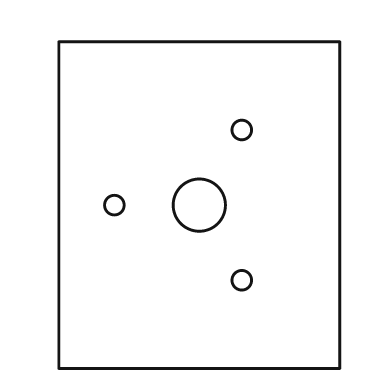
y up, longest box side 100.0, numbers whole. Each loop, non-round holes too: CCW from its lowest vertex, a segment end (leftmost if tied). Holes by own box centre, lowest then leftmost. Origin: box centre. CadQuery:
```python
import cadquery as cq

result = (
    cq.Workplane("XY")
    .moveTo(-43.0, -50.0)
    .lineTo(43.0, -50.0)
    .lineTo(43.0, 50.0)
    .lineTo(-43.0, 50.0)
    .close()
    .moveTo(13.0, -23.0)
    .circle(3.0)
    .moveTo(-26.0, 0.0)
    .circle(3.0)
    .moveTo(0.0, 0.0)
    .circle(8.0)
    .moveTo(13.0, 23.0)
    .circle(3.0)
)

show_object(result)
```